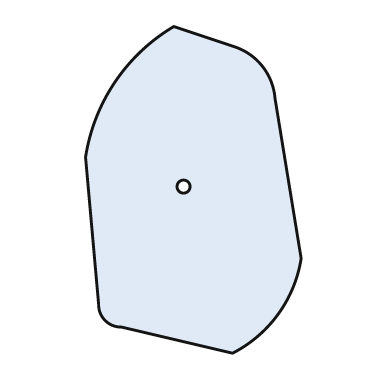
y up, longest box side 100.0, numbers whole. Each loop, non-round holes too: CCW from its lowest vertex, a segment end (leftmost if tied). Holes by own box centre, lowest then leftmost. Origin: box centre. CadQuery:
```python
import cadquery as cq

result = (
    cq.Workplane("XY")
    .moveTo(12.0, -50.0)
    .threePointArc((26.0, -38.0), (33.0, -21.0))
    .lineTo(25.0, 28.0)
    .threePointArc((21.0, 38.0), (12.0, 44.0))
    .lineTo(-6.0, 50.0)
    .threePointArc((-24.0, 33.0), (-33.0, 10.0))
    .lineTo(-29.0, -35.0)
    .threePointArc((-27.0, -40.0), (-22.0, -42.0))
    .close()
    .moveTo(-3.0, 1.0)
    .circle(2.0)
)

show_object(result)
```